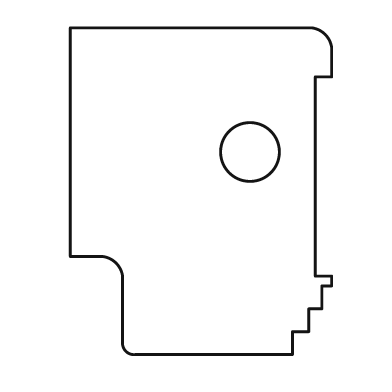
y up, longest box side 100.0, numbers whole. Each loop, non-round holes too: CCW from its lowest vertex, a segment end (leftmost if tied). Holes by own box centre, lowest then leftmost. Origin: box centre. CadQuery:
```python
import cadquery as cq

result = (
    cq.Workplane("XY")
    .moveTo(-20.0, -50.0)
    .lineTo(28.0, -50.0)
    .lineTo(28.0, -43.0)
    .lineTo(33.0, -43.0)
    .lineTo(33.0, -36.0)
    .lineTo(37.0, -36.0)
    .lineTo(37.0, -29.0)
    .lineTo(40.0, -29.0)
    .lineTo(40.0, -26.0)
    .lineTo(35.0, -26.0)
    .lineTo(35.0, 35.0)
    .lineTo(40.0, 35.0)
    .lineTo(40.0, 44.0)
    .threePointArc((38.0, 48.0), (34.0, 50.0))
    .lineTo(-40.0, 50.0)
    .lineTo(-40.0, -20.0)
    .lineTo(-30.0, -20.0)
    .threePointArc((-26.0, -22.0), (-24.0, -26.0))
    .lineTo(-24.0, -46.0)
    .threePointArc((-23.0, -49.0), (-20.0, -50.0))
    .close()
    .moveTo(15.0, 12.0)
    .circle(9.0)
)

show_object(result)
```